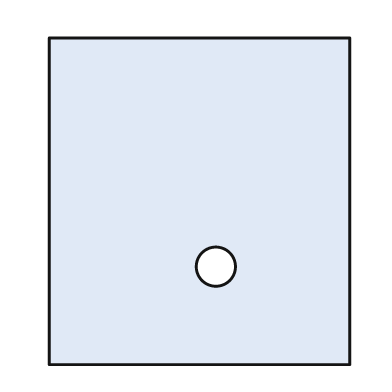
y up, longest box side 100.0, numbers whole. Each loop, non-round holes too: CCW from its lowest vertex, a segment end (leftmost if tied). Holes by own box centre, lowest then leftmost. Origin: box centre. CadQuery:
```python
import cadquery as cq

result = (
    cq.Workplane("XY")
    .moveTo(-46.0, -50.0)
    .lineTo(46.0, -50.0)
    .lineTo(46.0, 50.0)
    .lineTo(-46.0, 50.0)
    .close()
    .moveTo(5.0, -20.0)
    .circle(6.0)
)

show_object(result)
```